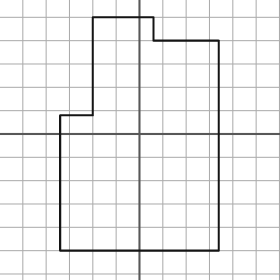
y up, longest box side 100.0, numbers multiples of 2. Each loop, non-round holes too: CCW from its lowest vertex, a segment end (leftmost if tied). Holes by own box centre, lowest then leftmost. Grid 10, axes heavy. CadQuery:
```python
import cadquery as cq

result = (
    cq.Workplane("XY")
    .moveTo(-34.0, -50.0)
    .lineTo(34.0, -50.0)
    .lineTo(34.0, 40.0)
    .lineTo(6.0, 40.0)
    .lineTo(6.0, 50.0)
    .lineTo(-20.0, 50.0)
    .lineTo(-20.0, 8.0)
    .lineTo(-34.0, 8.0)
    .close()
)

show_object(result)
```